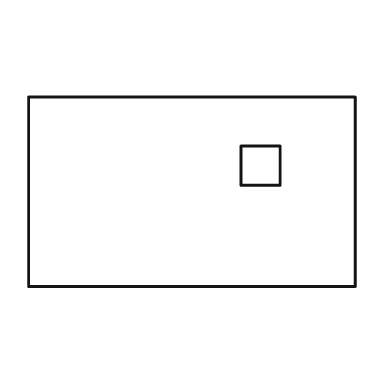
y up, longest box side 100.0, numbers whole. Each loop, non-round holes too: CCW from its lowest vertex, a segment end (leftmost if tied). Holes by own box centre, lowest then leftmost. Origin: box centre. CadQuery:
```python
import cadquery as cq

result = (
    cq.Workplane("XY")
    .moveTo(-50.0, -29.0)
    .lineTo(50.0, -29.0)
    .lineTo(50.0, 29.0)
    .lineTo(-50.0, 29.0)
    .close()
    .moveTo(15.0, 2.0)
    .lineTo(27.0, 2.0)
    .lineTo(27.0, 14.0)
    .lineTo(15.0, 14.0)
    .close()
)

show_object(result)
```